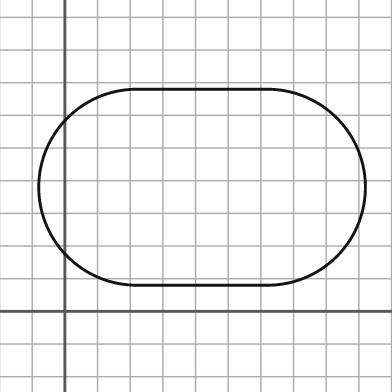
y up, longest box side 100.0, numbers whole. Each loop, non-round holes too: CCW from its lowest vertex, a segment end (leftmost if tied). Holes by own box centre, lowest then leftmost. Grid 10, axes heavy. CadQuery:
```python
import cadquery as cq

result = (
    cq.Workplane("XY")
    .moveTo(22.0, 8.0)
    .lineTo(62.0, 8.0)
    .threePointArc((92.0, 38.0), (62.0, 68.0))
    .lineTo(22.0, 68.0)
    .threePointArc((-8.0, 38.0), (22.0, 8.0))
    .close()
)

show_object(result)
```